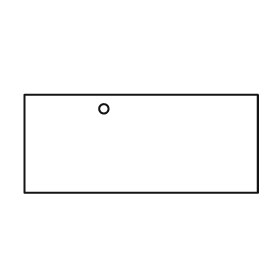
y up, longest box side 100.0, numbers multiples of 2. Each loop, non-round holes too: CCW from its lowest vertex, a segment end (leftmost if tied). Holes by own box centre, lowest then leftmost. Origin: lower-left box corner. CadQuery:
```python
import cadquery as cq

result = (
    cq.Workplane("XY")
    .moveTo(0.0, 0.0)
    .lineTo(100.0, 0.0)
    .lineTo(100.0, 42.0)
    .lineTo(0.0, 42.0)
    .close()
    .moveTo(34.0, 36.0)
    .circle(2.0)
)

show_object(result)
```